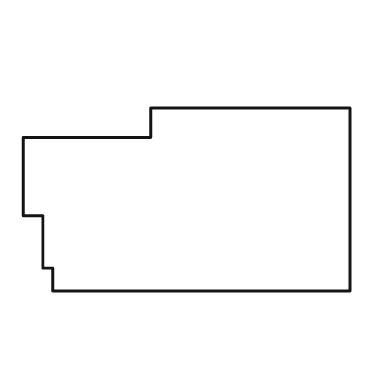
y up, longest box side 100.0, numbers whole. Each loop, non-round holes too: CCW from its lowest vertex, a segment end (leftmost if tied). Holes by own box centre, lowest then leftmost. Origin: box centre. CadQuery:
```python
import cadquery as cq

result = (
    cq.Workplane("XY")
    .moveTo(-41.0, -28.0)
    .lineTo(50.0, -28.0)
    .lineTo(50.0, 28.0)
    .lineTo(-11.0, 28.0)
    .lineTo(-11.0, 19.0)
    .lineTo(-50.0, 19.0)
    .lineTo(-50.0, -5.0)
    .lineTo(-44.0, -5.0)
    .lineTo(-44.0, -21.0)
    .lineTo(-41.0, -21.0)
    .close()
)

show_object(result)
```